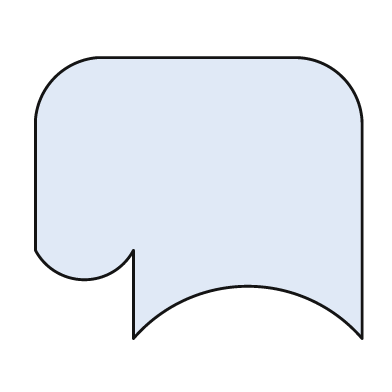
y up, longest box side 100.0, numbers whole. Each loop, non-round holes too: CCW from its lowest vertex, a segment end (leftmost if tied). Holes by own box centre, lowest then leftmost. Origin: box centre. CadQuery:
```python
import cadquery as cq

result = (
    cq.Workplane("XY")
    .moveTo(-20.0, -43.0)
    .threePointArc((15.0, -27.0), (50.0, -43.0))
    .lineTo(50.0, 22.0)
    .threePointArc((44.0, 37.0), (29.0, 43.0))
    .lineTo(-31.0, 43.0)
    .threePointArc((-44.0, 37.0), (-50.0, 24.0))
    .lineTo(-50.0, -16.0)
    .threePointArc((-35.0, -25.0), (-20.0, -16.0))
    .close()
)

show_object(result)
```